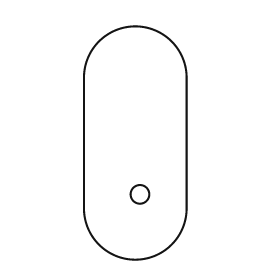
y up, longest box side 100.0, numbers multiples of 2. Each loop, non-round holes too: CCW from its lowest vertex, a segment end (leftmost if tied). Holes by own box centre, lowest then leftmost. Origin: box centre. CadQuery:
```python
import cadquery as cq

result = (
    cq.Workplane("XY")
    .moveTo(-22.0, -28.0)
    .threePointArc((0.0, -50.0), (22.0, -28.0))
    .lineTo(22.0, 28.0)
    .threePointArc((0.0, 50.0), (-22.0, 28.0))
    .close()
    .moveTo(2.0, -22.0)
    .circle(4.0)
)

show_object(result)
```